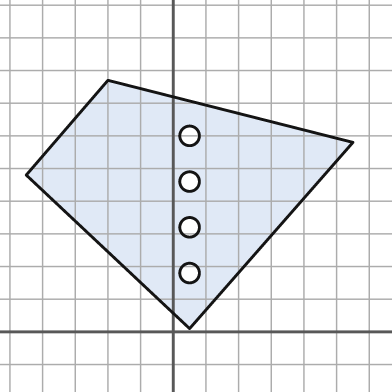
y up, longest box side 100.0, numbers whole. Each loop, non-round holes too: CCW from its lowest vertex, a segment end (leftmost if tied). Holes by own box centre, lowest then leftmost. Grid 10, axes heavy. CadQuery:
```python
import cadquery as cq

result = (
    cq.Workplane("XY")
    .moveTo(5.0, 1.0)
    .lineTo(55.0, 58.0)
    .lineTo(-20.0, 77.0)
    .lineTo(-45.0, 48.0)
    .close()
    .moveTo(5.0, 18.0)
    .circle(3.0)
    .moveTo(5.0, 32.0)
    .circle(3.0)
    .moveTo(5.0, 46.0)
    .circle(3.0)
    .moveTo(5.0, 60.0)
    .circle(3.0)
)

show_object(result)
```